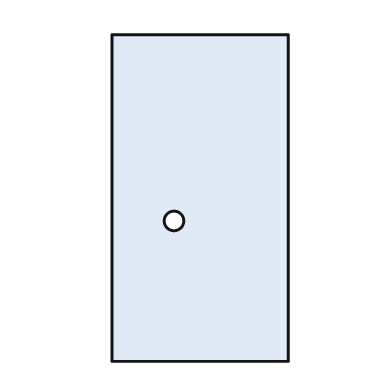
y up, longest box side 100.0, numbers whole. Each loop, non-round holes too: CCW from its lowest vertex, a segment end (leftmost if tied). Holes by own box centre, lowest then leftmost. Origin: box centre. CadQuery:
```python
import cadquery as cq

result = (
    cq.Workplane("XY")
    .moveTo(-27.0, -50.0)
    .lineTo(27.0, -50.0)
    .lineTo(27.0, 50.0)
    .lineTo(-27.0, 50.0)
    .close()
    .moveTo(-8.0, -7.0)
    .circle(3.0)
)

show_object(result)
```